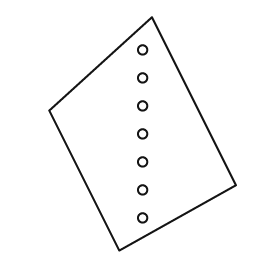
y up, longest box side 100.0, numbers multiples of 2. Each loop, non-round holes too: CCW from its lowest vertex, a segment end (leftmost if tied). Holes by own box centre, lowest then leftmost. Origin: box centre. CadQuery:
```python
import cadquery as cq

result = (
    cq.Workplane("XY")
    .moveTo(-10.0, -50.0)
    .lineTo(40.0, -22.0)
    .lineTo(4.0, 50.0)
    .lineTo(-40.0, 10.0)
    .close()
    .moveTo(0.0, -36.0)
    .circle(2.0)
    .moveTo(0.0, -24.0)
    .circle(2.0)
    .moveTo(0.0, -12.0)
    .circle(2.0)
    .moveTo(0.0, 0.0)
    .circle(2.0)
    .moveTo(0.0, 12.0)
    .circle(2.0)
    .moveTo(0.0, 24.0)
    .circle(2.0)
    .moveTo(0.0, 36.0)
    .circle(2.0)
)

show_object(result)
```